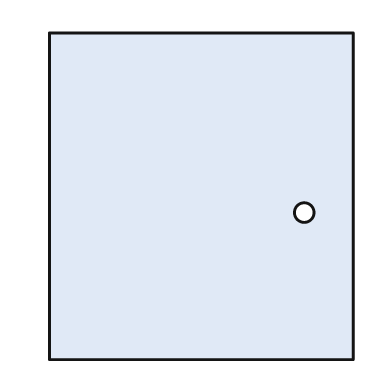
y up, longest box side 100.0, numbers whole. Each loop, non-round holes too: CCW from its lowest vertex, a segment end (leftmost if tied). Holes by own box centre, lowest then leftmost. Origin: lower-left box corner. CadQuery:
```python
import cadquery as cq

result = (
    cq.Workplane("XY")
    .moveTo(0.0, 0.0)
    .lineTo(93.0, 0.0)
    .lineTo(93.0, 100.0)
    .lineTo(0.0, 100.0)
    .close()
    .moveTo(78.0, 45.0)
    .circle(3.0)
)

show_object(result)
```